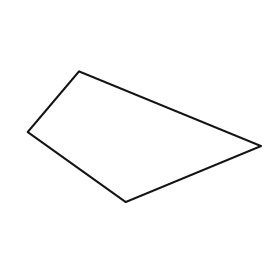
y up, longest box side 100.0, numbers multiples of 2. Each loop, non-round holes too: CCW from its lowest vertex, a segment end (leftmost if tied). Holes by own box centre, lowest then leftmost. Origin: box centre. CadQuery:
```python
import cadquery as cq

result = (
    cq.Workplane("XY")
    .moveTo(-8.0, -28.0)
    .lineTo(50.0, -4.0)
    .lineTo(-28.0, 28.0)
    .lineTo(-50.0, 2.0)
    .close()
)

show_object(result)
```